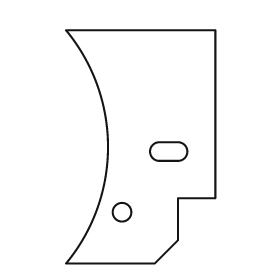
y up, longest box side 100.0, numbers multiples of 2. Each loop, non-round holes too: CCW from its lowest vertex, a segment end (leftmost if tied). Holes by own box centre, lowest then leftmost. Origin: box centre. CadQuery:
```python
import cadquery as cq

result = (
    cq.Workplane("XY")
    .moveTo(-32.0, -50.0)
    .lineTo(6.0, -50.0)
    .lineTo(16.0, -40.0)
    .lineTo(16.0, -22.0)
    .lineTo(32.0, -22.0)
    .lineTo(32.0, 50.0)
    .lineTo(-32.0, 50.0)
    .threePointArc((-14.0, 0.0), (-32.0, -50.0))
    .close()
    .moveTo(-8.0, -28.0)
    .circle(4.0)
    .moveTo(8.0, -6.0)
    .lineTo(16.0, -6.0)
    .threePointArc((20.0, -2.0), (16.0, 2.0))
    .lineTo(8.0, 2.0)
    .threePointArc((4.0, -2.0), (8.0, -6.0))
    .close()
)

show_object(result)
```